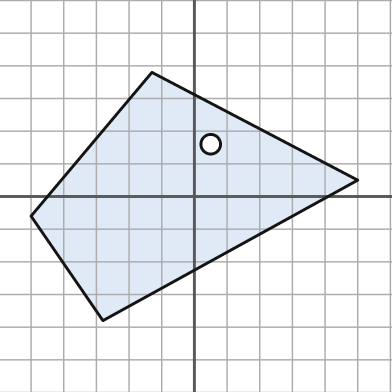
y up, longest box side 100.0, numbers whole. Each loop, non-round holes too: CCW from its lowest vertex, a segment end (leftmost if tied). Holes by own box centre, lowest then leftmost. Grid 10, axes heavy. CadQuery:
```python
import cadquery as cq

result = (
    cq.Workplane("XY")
    .moveTo(-28.0, -38.0)
    .lineTo(50.0, 5.0)
    .lineTo(-13.0, 38.0)
    .lineTo(-50.0, -6.0)
    .close()
    .moveTo(5.0, 16.0)
    .circle(3.0)
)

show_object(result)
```